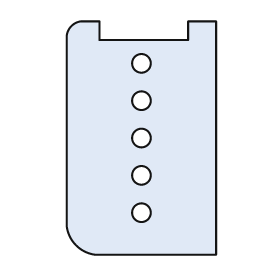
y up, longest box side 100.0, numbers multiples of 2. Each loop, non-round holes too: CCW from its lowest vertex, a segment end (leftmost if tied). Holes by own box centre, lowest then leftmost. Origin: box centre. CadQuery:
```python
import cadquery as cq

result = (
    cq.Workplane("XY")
    .moveTo(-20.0, -50.0)
    .lineTo(32.0, -50.0)
    .lineTo(32.0, 50.0)
    .lineTo(20.0, 50.0)
    .lineTo(20.0, 42.0)
    .lineTo(-18.0, 42.0)
    .lineTo(-18.0, 50.0)
    .lineTo(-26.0, 50.0)
    .threePointArc((-30.0, 48.0), (-32.0, 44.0))
    .lineTo(-32.0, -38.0)
    .threePointArc((-28.0, -46.0), (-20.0, -50.0))
    .close()
    .moveTo(0.0, -32.0)
    .circle(4.0)
    .moveTo(0.0, -16.0)
    .circle(4.0)
    .moveTo(0.0, 0.0)
    .circle(4.0)
    .moveTo(0.0, 16.0)
    .circle(4.0)
    .moveTo(0.0, 32.0)
    .circle(4.0)
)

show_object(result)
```